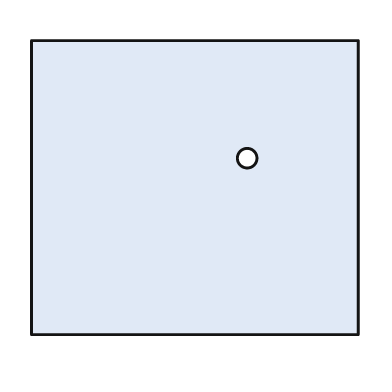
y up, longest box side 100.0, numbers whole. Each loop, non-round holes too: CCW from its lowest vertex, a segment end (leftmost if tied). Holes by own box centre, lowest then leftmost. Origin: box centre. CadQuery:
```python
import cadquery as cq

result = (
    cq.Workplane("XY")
    .moveTo(-50.0, -45.0)
    .lineTo(50.0, -45.0)
    .lineTo(50.0, 45.0)
    .lineTo(-50.0, 45.0)
    .close()
    .moveTo(16.0, 9.0)
    .circle(3.0)
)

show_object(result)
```